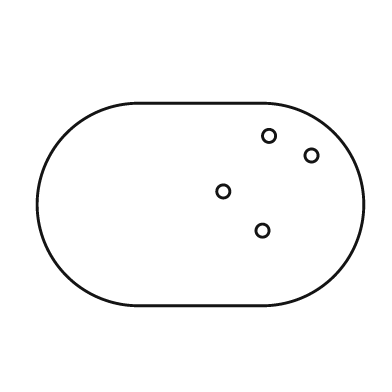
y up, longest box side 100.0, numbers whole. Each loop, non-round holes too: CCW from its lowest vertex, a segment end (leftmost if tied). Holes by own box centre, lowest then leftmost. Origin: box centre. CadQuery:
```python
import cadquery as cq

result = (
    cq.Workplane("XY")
    .moveTo(-19.0, -31.0)
    .lineTo(19.0, -31.0)
    .threePointArc((50.0, 0.0), (19.0, 31.0))
    .lineTo(-19.0, 31.0)
    .threePointArc((-50.0, 0.0), (-19.0, -31.0))
    .close()
    .moveTo(19.0, -8.0)
    .circle(2.0)
    .moveTo(7.0, 4.0)
    .circle(2.0)
    .moveTo(34.0, 15.0)
    .circle(2.0)
    .moveTo(21.0, 21.0)
    .circle(2.0)
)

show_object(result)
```